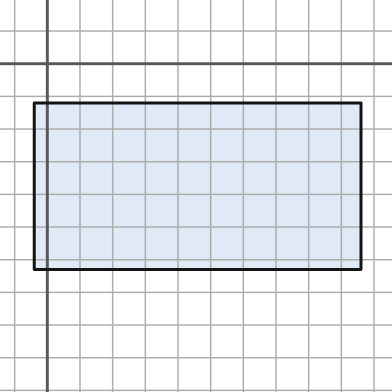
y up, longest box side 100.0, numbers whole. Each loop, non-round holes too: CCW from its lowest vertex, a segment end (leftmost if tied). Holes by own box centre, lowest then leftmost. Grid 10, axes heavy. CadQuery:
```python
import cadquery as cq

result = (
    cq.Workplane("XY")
    .moveTo(-4.0, -63.0)
    .lineTo(96.0, -63.0)
    .lineTo(96.0, -12.0)
    .lineTo(-4.0, -12.0)
    .close()
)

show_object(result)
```